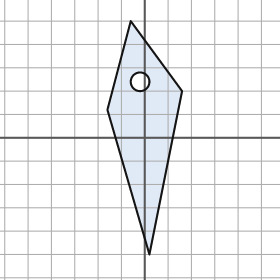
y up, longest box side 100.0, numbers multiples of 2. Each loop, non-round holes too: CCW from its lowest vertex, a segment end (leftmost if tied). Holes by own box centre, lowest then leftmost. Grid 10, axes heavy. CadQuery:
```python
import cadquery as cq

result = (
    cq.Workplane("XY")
    .moveTo(2.0, -50.0)
    .lineTo(16.0, 20.0)
    .lineTo(-6.0, 50.0)
    .lineTo(-16.0, 12.0)
    .close()
    .moveTo(-2.0, 24.0)
    .circle(4.0)
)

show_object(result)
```